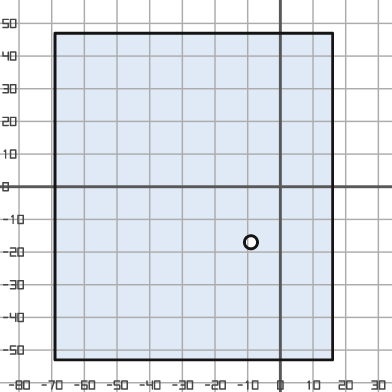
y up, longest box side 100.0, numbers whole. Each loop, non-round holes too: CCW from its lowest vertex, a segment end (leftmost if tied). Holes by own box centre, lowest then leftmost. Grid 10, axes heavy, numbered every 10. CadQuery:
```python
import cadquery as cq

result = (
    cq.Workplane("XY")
    .moveTo(-69.0, -53.0)
    .lineTo(16.0, -53.0)
    .lineTo(16.0, 47.0)
    .lineTo(-69.0, 47.0)
    .close()
    .moveTo(-9.0, -17.0)
    .circle(2.0)
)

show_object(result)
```